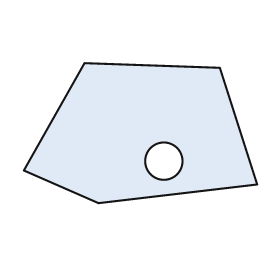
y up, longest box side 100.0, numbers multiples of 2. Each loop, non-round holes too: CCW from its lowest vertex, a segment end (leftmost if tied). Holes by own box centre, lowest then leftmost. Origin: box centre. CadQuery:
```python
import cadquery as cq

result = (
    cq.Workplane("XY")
    .moveTo(-18.0, -30.0)
    .lineTo(50.0, -22.0)
    .lineTo(34.0, 28.0)
    .lineTo(-24.0, 30.0)
    .lineTo(-50.0, -16.0)
    .close()
    .moveTo(10.0, -12.0)
    .circle(8.0)
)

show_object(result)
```